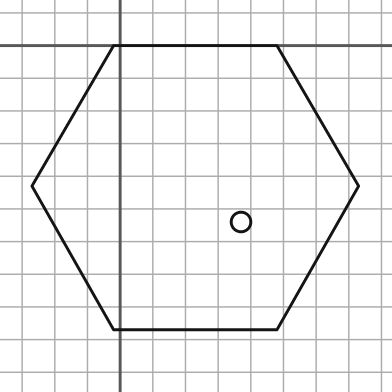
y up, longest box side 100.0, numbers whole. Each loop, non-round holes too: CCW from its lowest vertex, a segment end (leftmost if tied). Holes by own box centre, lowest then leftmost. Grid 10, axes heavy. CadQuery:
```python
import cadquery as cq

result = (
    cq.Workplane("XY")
    .moveTo(-2.0, -87.0)
    .lineTo(48.0, -87.0)
    .lineTo(73.0, -43.0)
    .lineTo(48.0, 0.0)
    .lineTo(-2.0, 0.0)
    .lineTo(-27.0, -43.0)
    .close()
    .moveTo(37.0, -54.0)
    .circle(3.0)
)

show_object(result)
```